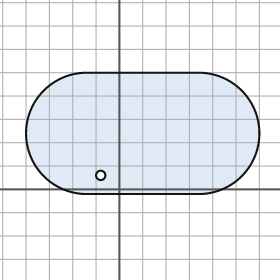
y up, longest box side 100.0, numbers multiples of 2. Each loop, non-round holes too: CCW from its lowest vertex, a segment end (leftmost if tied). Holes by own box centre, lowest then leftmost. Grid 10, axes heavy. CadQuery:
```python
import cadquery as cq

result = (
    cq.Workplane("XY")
    .moveTo(-14.0, -2.0)
    .lineTo(34.0, -2.0)
    .threePointArc((60.0, 24.0), (34.0, 50.0))
    .lineTo(-14.0, 50.0)
    .threePointArc((-40.0, 24.0), (-14.0, -2.0))
    .close()
    .moveTo(-8.0, 6.0)
    .circle(2.0)
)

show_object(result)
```